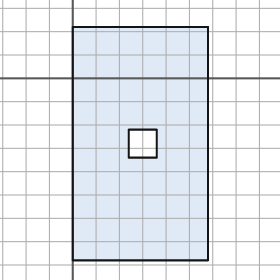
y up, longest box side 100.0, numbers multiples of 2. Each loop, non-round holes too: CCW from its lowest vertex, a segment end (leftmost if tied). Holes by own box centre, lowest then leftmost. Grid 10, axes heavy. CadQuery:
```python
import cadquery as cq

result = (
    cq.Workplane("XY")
    .moveTo(0.0, -78.0)
    .lineTo(58.0, -78.0)
    .lineTo(58.0, 22.0)
    .lineTo(0.0, 22.0)
    .close()
    .moveTo(24.0, -34.0)
    .lineTo(36.0, -34.0)
    .lineTo(36.0, -22.0)
    .lineTo(24.0, -22.0)
    .close()
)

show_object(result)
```